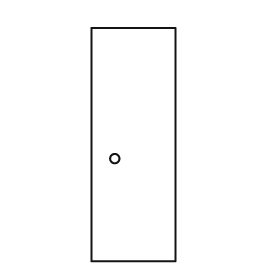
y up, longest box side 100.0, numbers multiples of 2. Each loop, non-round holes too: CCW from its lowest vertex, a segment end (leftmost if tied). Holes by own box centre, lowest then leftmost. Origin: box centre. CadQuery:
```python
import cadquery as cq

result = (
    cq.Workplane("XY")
    .moveTo(-18.0, -50.0)
    .lineTo(18.0, -50.0)
    .lineTo(18.0, 50.0)
    .lineTo(-18.0, 50.0)
    .close()
    .moveTo(-8.0, -6.0)
    .circle(2.0)
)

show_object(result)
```